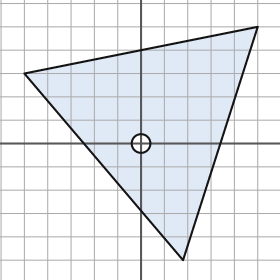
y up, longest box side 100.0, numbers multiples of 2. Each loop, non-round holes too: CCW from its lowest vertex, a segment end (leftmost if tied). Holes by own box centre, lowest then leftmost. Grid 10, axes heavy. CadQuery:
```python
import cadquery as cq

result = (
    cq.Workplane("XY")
    .moveTo(18.0, -50.0)
    .lineTo(50.0, 50.0)
    .lineTo(-50.0, 30.0)
    .close()
    .moveTo(0.0, 0.0)
    .circle(4.0)
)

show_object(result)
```